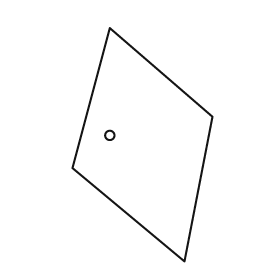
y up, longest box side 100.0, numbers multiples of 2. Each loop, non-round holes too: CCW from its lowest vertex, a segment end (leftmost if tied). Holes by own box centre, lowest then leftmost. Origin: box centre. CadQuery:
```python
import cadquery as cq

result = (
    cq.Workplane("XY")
    .moveTo(18.0, -50.0)
    .lineTo(30.0, 12.0)
    .lineTo(-14.0, 50.0)
    .lineTo(-30.0, -10.0)
    .close()
    .moveTo(-14.0, 4.0)
    .circle(2.0)
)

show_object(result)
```